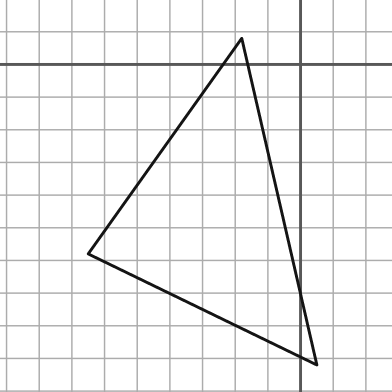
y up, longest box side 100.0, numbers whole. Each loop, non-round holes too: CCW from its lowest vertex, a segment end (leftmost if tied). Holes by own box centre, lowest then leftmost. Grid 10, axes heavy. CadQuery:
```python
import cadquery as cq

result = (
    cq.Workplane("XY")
    .moveTo(5.0, -92.0)
    .lineTo(-18.0, 8.0)
    .lineTo(-65.0, -58.0)
    .close()
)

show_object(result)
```